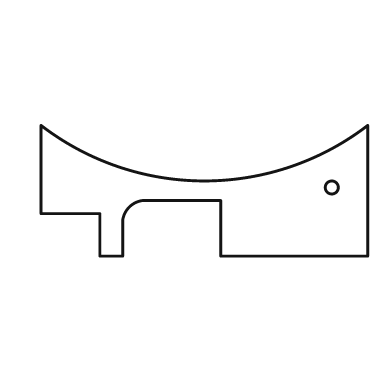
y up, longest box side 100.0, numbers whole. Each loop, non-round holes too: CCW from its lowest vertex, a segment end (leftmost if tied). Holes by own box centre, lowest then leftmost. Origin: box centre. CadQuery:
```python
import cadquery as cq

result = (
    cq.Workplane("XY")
    .moveTo(-32.0, -20.0)
    .lineTo(-25.0, -20.0)
    .lineTo(-25.0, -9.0)
    .threePointArc((-23.0, -5.0), (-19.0, -3.0))
    .lineTo(5.0, -3.0)
    .lineTo(5.0, -20.0)
    .lineTo(50.0, -20.0)
    .lineTo(50.0, 20.0)
    .threePointArc((0.0, 3.0), (-50.0, 20.0))
    .lineTo(-50.0, -7.0)
    .lineTo(-32.0, -7.0)
    .close()
    .moveTo(39.0, 1.0)
    .circle(2.0)
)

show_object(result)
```